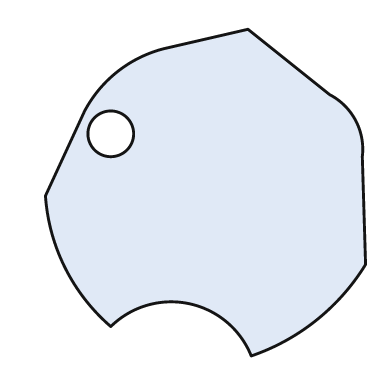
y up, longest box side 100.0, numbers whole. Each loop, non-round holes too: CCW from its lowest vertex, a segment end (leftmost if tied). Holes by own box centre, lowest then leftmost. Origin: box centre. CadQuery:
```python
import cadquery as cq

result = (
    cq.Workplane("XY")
    .moveTo(14.0, -50.0)
    .threePointArc((34.0, -39.0), (49.0, -22.0))
    .lineTo(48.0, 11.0)
    .threePointArc((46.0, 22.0), (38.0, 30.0))
    .lineTo(13.0, 50.0)
    .lineTo(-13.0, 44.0)
    .threePointArc((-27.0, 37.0), (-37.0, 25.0))
    .lineTo(-49.0, -1.0)
    .threePointArc((-43.0, -23.0), (-29.0, -41.0))
    .threePointArc((-5.0, -34.0), (14.0, -50.0))
    .close()
    .moveTo(-29.0, 18.0)
    .circle(7.0)
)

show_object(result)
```